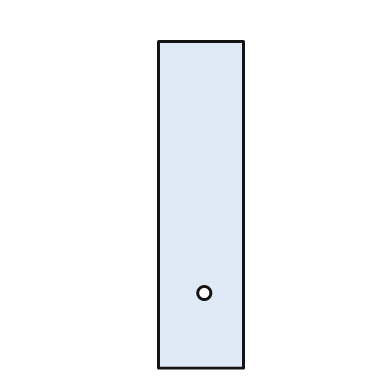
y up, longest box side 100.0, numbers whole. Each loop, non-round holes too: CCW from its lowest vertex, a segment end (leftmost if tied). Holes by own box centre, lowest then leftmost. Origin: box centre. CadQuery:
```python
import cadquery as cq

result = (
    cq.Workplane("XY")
    .moveTo(-13.0, -50.0)
    .lineTo(13.0, -50.0)
    .lineTo(13.0, 50.0)
    .lineTo(-13.0, 50.0)
    .close()
    .moveTo(1.0, -27.0)
    .circle(2.0)
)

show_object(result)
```